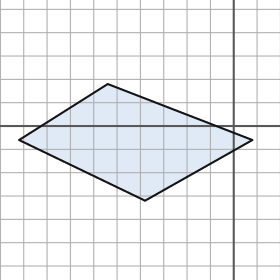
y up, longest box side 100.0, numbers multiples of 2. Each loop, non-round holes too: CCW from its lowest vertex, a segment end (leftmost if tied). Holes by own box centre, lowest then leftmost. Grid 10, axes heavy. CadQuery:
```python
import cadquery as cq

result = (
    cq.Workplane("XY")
    .moveTo(-38.0, -32.0)
    .lineTo(8.0, -6.0)
    .lineTo(-54.0, 18.0)
    .lineTo(-92.0, -6.0)
    .close()
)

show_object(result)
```